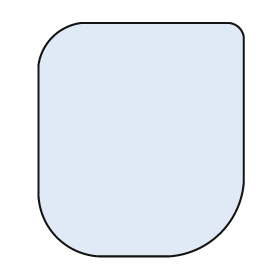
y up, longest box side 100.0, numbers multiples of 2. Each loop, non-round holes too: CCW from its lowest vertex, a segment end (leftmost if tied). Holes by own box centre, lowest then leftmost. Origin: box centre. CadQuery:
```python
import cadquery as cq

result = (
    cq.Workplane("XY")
    .moveTo(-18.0, -50.0)
    .lineTo(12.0, -50.0)
    .threePointArc((34.0, -40.0), (44.0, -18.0))
    .lineTo(44.0, 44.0)
    .threePointArc((42.0, 48.0), (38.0, 50.0))
    .lineTo(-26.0, 50.0)
    .threePointArc((-38.0, 44.0), (-44.0, 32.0))
    .lineTo(-44.0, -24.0)
    .threePointArc((-36.0, -42.0), (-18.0, -50.0))
    .close()
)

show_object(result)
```